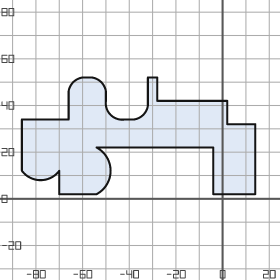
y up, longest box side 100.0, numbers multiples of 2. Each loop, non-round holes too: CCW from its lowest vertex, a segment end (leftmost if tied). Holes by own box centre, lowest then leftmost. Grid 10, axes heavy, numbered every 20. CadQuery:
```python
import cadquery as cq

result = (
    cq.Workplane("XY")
    .moveTo(-70.0, 2.0)
    .lineTo(-54.0, 2.0)
    .threePointArc((-48.0, 12.0), (-54.0, 22.0))
    .lineTo(-4.0, 22.0)
    .lineTo(-4.0, 2.0)
    .lineTo(14.0, 2.0)
    .lineTo(14.0, 32.0)
    .lineTo(2.0, 32.0)
    .lineTo(2.0, 42.0)
    .lineTo(-28.0, 42.0)
    .lineTo(-28.0, 52.0)
    .lineTo(-32.0, 52.0)
    .lineTo(-32.0, 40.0)
    .threePointArc((-34.0, 36.0), (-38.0, 34.0))
    .lineTo(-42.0, 34.0)
    .threePointArc((-48.0, 36.0), (-50.0, 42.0))
    .lineTo(-50.0, 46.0)
    .threePointArc((-52.0, 50.0), (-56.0, 52.0))
    .lineTo(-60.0, 52.0)
    .threePointArc((-64.0, 50.0), (-66.0, 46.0))
    .lineTo(-66.0, 34.0)
    .lineTo(-86.0, 34.0)
    .lineTo(-86.0, 12.0)
    .threePointArc((-78.0, 8.0), (-70.0, 12.0))
    .close()
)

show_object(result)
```